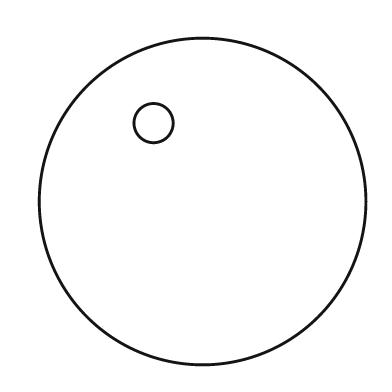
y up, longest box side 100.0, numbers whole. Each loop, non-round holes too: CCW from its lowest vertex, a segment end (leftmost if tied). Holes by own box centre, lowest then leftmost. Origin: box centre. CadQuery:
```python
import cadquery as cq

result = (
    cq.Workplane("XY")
    .moveTo(0.0, 0.0)
    .circle(50.0)
    .moveTo(-15.0, 24.0)
    .circle(6.0)
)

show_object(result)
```